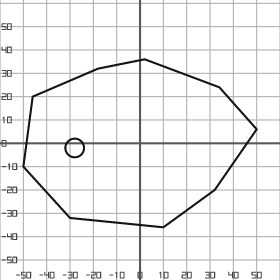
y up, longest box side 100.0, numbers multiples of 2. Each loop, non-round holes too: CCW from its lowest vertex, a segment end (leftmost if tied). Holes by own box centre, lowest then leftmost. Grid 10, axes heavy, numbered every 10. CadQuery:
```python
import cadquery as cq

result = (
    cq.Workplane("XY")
    .moveTo(10.0, -36.0)
    .lineTo(32.0, -20.0)
    .lineTo(50.0, 6.0)
    .lineTo(34.0, 24.0)
    .lineTo(2.0, 36.0)
    .lineTo(-18.0, 32.0)
    .lineTo(-46.0, 20.0)
    .lineTo(-50.0, -10.0)
    .lineTo(-30.0, -32.0)
    .close()
    .moveTo(-28.0, -2.0)
    .circle(4.0)
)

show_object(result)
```